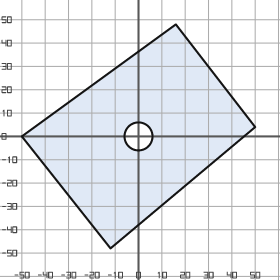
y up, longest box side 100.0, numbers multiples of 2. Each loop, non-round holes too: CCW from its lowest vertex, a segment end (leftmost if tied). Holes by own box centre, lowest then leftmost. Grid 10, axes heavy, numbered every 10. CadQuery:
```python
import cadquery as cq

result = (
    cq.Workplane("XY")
    .moveTo(-12.0, -48.0)
    .lineTo(50.0, 4.0)
    .lineTo(16.0, 48.0)
    .lineTo(-50.0, 0.0)
    .close()
    .moveTo(0.0, 0.0)
    .circle(6.0)
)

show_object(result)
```